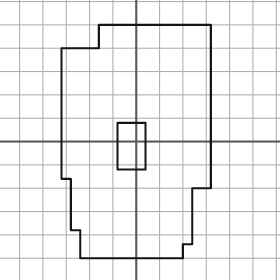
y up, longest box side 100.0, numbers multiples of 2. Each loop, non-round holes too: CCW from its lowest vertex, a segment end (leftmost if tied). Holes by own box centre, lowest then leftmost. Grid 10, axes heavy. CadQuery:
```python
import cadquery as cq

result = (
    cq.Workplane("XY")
    .moveTo(-24.0, -50.0)
    .lineTo(20.0, -50.0)
    .lineTo(20.0, -44.0)
    .lineTo(24.0, -44.0)
    .lineTo(24.0, -20.0)
    .lineTo(32.0, -20.0)
    .lineTo(32.0, 50.0)
    .lineTo(-16.0, 50.0)
    .lineTo(-16.0, 40.0)
    .lineTo(-32.0, 40.0)
    .lineTo(-32.0, -16.0)
    .lineTo(-28.0, -16.0)
    .lineTo(-28.0, -38.0)
    .lineTo(-24.0, -38.0)
    .close()
    .moveTo(-8.0, -12.0)
    .lineTo(4.0, -12.0)
    .lineTo(4.0, 8.0)
    .lineTo(-8.0, 8.0)
    .close()
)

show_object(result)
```